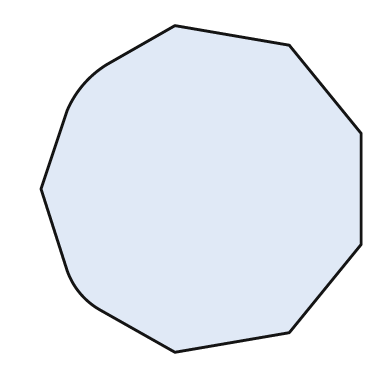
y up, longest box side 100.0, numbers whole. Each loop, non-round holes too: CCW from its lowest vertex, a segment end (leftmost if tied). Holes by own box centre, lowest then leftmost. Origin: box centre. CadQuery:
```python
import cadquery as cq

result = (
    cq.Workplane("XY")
    .moveTo(-8.0, -50.0)
    .lineTo(27.0, -44.0)
    .lineTo(49.0, -17.0)
    .lineTo(49.0, 17.0)
    .lineTo(27.0, 44.0)
    .lineTo(-8.0, 50.0)
    .lineTo(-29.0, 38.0)
    .threePointArc((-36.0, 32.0), (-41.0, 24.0))
    .lineTo(-49.0, 0.0)
    .lineTo(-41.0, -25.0)
    .threePointArc((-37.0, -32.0), (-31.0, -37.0))
    .close()
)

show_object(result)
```